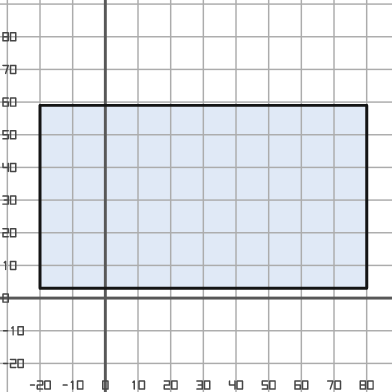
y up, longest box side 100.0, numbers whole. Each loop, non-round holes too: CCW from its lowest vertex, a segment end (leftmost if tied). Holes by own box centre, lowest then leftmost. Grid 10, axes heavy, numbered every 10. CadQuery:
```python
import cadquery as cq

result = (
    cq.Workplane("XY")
    .moveTo(-20.0, 3.0)
    .lineTo(80.0, 3.0)
    .lineTo(80.0, 59.0)
    .lineTo(-20.0, 59.0)
    .close()
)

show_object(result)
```